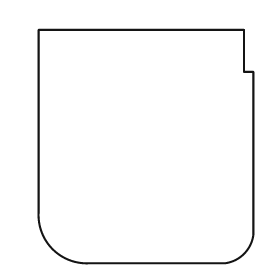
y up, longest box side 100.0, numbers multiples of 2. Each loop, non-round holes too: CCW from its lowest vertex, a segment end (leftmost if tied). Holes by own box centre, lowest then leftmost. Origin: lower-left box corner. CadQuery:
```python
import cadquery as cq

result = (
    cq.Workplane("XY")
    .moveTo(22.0, 0.0)
    .lineTo(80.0, 0.0)
    .threePointArc((88.0, 4.0), (92.0, 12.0))
    .lineTo(92.0, 82.0)
    .lineTo(88.0, 82.0)
    .lineTo(88.0, 100.0)
    .lineTo(0.0, 100.0)
    .lineTo(0.0, 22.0)
    .threePointArc((6.0, 6.0), (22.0, 0.0))
    .close()
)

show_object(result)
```